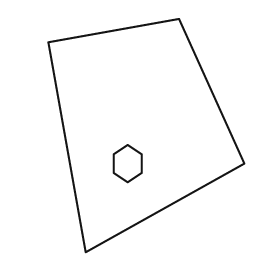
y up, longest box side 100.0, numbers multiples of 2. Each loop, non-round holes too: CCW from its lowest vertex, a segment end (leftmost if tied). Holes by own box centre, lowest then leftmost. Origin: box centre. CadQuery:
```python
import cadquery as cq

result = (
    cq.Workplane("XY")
    .moveTo(-26.0, -50.0)
    .lineTo(42.0, -12.0)
    .lineTo(14.0, 50.0)
    .lineTo(-42.0, 40.0)
    .close()
    .moveTo(-8.0, -20.0)
    .lineTo(-2.0, -16.0)
    .lineTo(-2.0, -8.0)
    .lineTo(-8.0, -4.0)
    .lineTo(-14.0, -8.0)
    .lineTo(-14.0, -16.0)
    .close()
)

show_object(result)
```